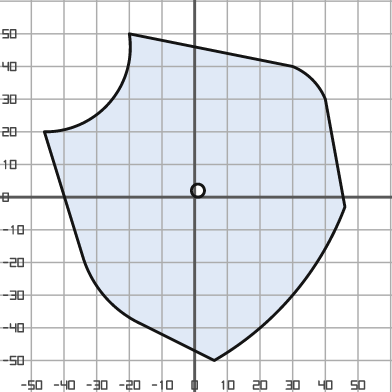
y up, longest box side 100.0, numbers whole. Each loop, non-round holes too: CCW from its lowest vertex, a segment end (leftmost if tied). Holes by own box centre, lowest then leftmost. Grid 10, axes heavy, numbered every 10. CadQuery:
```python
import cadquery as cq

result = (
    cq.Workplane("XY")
    .moveTo(6.0, -50.0)
    .threePointArc((30.0, -30.0), (46.0, -3.0))
    .lineTo(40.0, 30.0)
    .threePointArc((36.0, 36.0), (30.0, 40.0))
    .lineTo(-20.0, 50.0)
    .threePointArc((-26.0, 29.0), (-46.0, 20.0))
    .lineTo(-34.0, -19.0)
    .threePointArc((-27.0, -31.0), (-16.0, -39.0))
    .close()
    .moveTo(1.0, 2.0)
    .circle(2.0)
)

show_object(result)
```